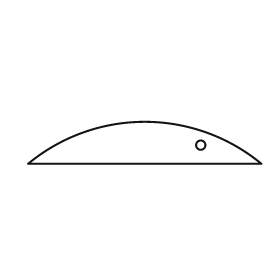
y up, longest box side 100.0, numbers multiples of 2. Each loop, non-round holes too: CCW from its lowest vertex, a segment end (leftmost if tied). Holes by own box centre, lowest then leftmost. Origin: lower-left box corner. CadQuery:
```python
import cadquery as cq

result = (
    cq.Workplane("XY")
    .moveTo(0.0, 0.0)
    .lineTo(100.0, 0.0)
    .threePointArc((50.0, 18.0), (0.0, 0.0))
    .close()
    .moveTo(74.0, 8.0)
    .circle(2.0)
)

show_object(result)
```